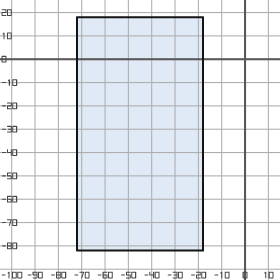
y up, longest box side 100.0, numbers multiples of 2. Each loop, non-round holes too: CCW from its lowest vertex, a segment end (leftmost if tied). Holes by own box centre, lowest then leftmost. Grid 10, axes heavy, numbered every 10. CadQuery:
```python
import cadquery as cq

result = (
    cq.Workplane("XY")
    .moveTo(-72.0, -82.0)
    .lineTo(-18.0, -82.0)
    .lineTo(-18.0, 18.0)
    .lineTo(-72.0, 18.0)
    .close()
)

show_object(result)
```